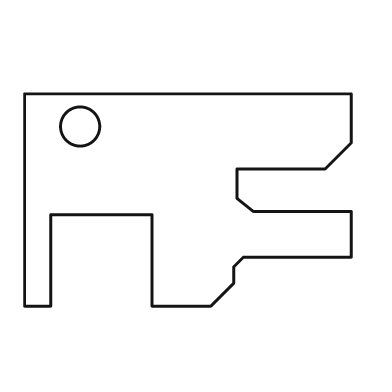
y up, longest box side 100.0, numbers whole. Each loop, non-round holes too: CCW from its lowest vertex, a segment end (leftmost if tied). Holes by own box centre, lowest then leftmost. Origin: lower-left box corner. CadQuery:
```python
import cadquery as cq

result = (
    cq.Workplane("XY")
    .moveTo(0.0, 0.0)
    .lineTo(8.0, 0.0)
    .lineTo(8.0, 28.0)
    .lineTo(39.0, 28.0)
    .lineTo(39.0, 0.0)
    .lineTo(57.0, 0.0)
    .lineTo(64.0, 7.0)
    .lineTo(64.0, 12.0)
    .lineTo(67.0, 15.0)
    .lineTo(100.0, 15.0)
    .lineTo(100.0, 29.0)
    .lineTo(70.0, 29.0)
    .lineTo(65.0, 33.0)
    .lineTo(65.0, 42.0)
    .lineTo(92.0, 42.0)
    .lineTo(100.0, 50.0)
    .lineTo(100.0, 65.0)
    .lineTo(0.0, 65.0)
    .close()
    .moveTo(17.0, 55.0)
    .circle(6.0)
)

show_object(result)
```